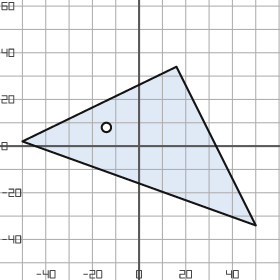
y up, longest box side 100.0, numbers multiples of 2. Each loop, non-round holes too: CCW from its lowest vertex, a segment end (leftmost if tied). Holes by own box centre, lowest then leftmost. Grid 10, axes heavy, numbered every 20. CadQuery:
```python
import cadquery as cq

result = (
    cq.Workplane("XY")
    .moveTo(50.0, -34.0)
    .lineTo(16.0, 34.0)
    .lineTo(-50.0, 2.0)
    .close()
    .moveTo(-14.0, 8.0)
    .circle(2.0)
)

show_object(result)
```